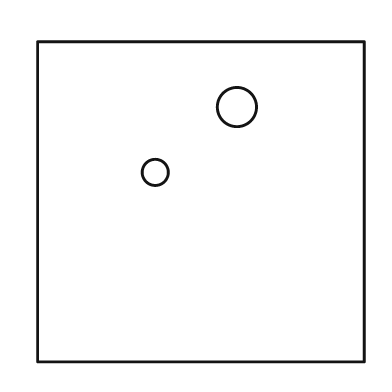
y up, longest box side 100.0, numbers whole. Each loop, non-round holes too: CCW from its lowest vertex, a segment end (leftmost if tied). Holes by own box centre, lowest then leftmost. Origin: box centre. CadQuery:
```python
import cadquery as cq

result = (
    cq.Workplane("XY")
    .moveTo(-50.0, -49.0)
    .lineTo(50.0, -49.0)
    .lineTo(50.0, 49.0)
    .lineTo(-50.0, 49.0)
    .close()
    .moveTo(-14.0, 9.0)
    .circle(4.0)
    .moveTo(11.0, 29.0)
    .circle(6.0)
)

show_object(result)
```